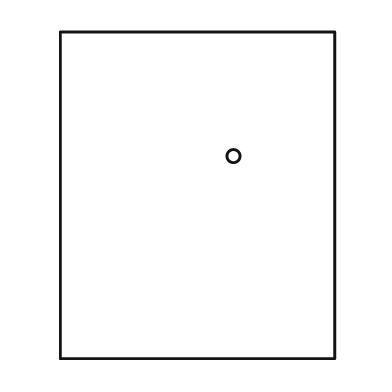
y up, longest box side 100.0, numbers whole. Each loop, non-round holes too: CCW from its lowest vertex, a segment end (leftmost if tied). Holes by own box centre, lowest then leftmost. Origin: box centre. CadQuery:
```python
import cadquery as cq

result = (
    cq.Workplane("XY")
    .moveTo(-42.0, -50.0)
    .lineTo(42.0, -50.0)
    .lineTo(42.0, 50.0)
    .lineTo(-42.0, 50.0)
    .close()
    .moveTo(11.0, 12.0)
    .circle(2.0)
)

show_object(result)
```